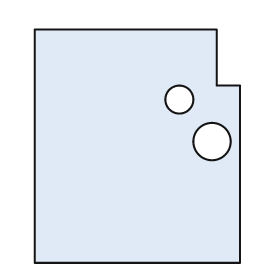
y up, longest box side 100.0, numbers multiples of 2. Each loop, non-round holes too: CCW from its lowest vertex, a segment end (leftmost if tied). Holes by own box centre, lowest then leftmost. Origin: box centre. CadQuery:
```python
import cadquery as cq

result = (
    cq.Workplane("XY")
    .moveTo(-44.0, -50.0)
    .lineTo(44.0, -50.0)
    .lineTo(44.0, 26.0)
    .lineTo(34.0, 26.0)
    .lineTo(34.0, 50.0)
    .lineTo(-44.0, 50.0)
    .close()
    .moveTo(32.0, 2.0)
    .circle(8.0)
    .moveTo(18.0, 20.0)
    .circle(6.0)
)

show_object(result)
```